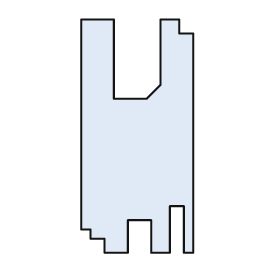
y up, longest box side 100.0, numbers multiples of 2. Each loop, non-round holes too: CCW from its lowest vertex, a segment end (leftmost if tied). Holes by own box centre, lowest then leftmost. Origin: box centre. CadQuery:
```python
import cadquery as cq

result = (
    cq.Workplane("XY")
    .moveTo(-14.0, -50.0)
    .lineTo(-4.0, -50.0)
    .lineTo(-4.0, -36.0)
    .lineTo(6.0, -36.0)
    .lineTo(6.0, -50.0)
    .lineTo(14.0, -50.0)
    .lineTo(14.0, -30.0)
    .lineTo(20.0, -30.0)
    .lineTo(20.0, -50.0)
    .lineTo(24.0, -50.0)
    .lineTo(24.0, 44.0)
    .lineTo(18.0, 44.0)
    .lineTo(18.0, 50.0)
    .lineTo(10.0, 50.0)
    .lineTo(10.0, 22.0)
    .lineTo(4.0, 16.0)
    .lineTo(-10.0, 16.0)
    .lineTo(-10.0, 50.0)
    .lineTo(-24.0, 50.0)
    .lineTo(-24.0, -40.0)
    .lineTo(-20.0, -40.0)
    .lineTo(-20.0, -44.0)
    .lineTo(-14.0, -44.0)
    .close()
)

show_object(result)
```